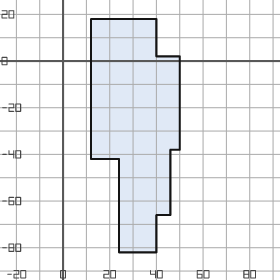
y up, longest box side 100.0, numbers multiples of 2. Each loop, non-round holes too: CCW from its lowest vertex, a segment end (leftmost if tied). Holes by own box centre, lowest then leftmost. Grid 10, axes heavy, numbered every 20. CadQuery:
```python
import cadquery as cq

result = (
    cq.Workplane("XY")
    .moveTo(24.0, -82.0)
    .lineTo(40.0, -82.0)
    .lineTo(40.0, -66.0)
    .lineTo(46.0, -66.0)
    .lineTo(46.0, -38.0)
    .lineTo(50.0, -38.0)
    .lineTo(50.0, 2.0)
    .lineTo(40.0, 2.0)
    .lineTo(40.0, 18.0)
    .lineTo(12.0, 18.0)
    .lineTo(12.0, -42.0)
    .lineTo(24.0, -42.0)
    .close()
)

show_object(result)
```